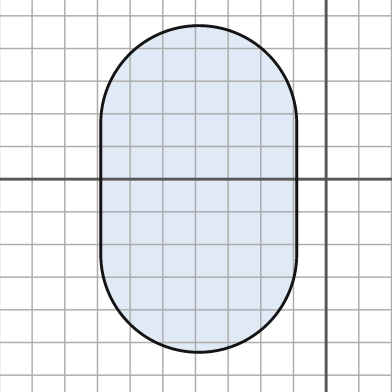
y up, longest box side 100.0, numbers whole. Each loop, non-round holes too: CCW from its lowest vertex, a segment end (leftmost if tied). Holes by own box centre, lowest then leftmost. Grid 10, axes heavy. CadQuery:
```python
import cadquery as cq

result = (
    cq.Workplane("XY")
    .moveTo(-69.0, -23.0)
    .threePointArc((-39.0, -53.0), (-9.0, -23.0))
    .lineTo(-9.0, 17.0)
    .threePointArc((-39.0, 47.0), (-69.0, 17.0))
    .close()
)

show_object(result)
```